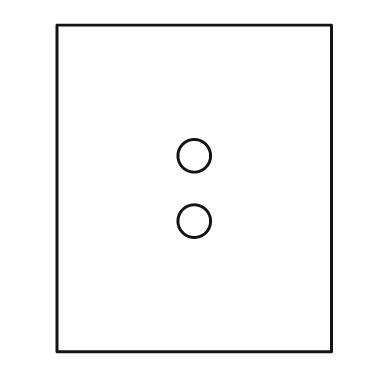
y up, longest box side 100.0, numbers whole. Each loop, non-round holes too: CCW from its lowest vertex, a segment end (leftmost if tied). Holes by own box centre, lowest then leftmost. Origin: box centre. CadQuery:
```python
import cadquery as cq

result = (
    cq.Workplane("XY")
    .moveTo(-42.0, -50.0)
    .lineTo(42.0, -50.0)
    .lineTo(42.0, 50.0)
    .lineTo(-42.0, 50.0)
    .close()
    .moveTo(0.0, -10.0)
    .circle(5.0)
    .moveTo(0.0, 10.0)
    .circle(5.0)
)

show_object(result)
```